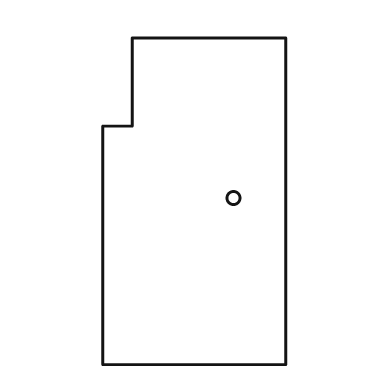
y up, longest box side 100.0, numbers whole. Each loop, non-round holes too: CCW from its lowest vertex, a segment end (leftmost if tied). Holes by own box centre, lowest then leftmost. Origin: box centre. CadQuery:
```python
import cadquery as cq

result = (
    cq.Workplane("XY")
    .moveTo(-28.0, -50.0)
    .lineTo(28.0, -50.0)
    .lineTo(28.0, 50.0)
    .lineTo(-19.0, 50.0)
    .lineTo(-19.0, 23.0)
    .lineTo(-28.0, 23.0)
    .close()
    .moveTo(12.0, 1.0)
    .circle(2.0)
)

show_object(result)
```